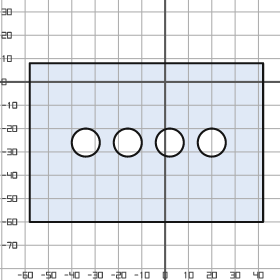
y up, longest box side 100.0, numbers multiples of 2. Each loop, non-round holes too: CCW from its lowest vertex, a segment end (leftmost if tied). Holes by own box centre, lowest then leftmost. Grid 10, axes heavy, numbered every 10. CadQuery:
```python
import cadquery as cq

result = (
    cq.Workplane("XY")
    .moveTo(-58.0, -60.0)
    .lineTo(42.0, -60.0)
    .lineTo(42.0, 8.0)
    .lineTo(-58.0, 8.0)
    .close()
    .moveTo(-34.0, -26.0)
    .circle(6.0)
    .moveTo(-16.0, -26.0)
    .circle(6.0)
    .moveTo(2.0, -26.0)
    .circle(6.0)
    .moveTo(20.0, -26.0)
    .circle(6.0)
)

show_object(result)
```